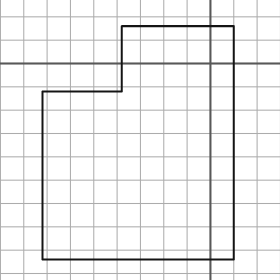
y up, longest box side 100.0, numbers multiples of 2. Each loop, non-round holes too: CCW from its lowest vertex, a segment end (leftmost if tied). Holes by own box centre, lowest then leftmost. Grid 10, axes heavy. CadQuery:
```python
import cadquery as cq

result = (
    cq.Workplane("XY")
    .moveTo(-72.0, -84.0)
    .lineTo(10.0, -84.0)
    .lineTo(10.0, 16.0)
    .lineTo(-38.0, 16.0)
    .lineTo(-38.0, -12.0)
    .lineTo(-72.0, -12.0)
    .close()
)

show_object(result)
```